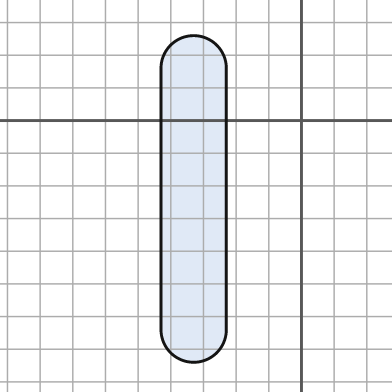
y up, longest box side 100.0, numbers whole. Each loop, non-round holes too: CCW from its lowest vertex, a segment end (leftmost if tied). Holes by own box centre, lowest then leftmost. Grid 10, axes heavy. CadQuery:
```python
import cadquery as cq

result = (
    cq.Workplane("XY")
    .moveTo(-43.0, -64.0)
    .threePointArc((-33.0, -74.0), (-23.0, -64.0))
    .lineTo(-23.0, 16.0)
    .threePointArc((-33.0, 26.0), (-43.0, 16.0))
    .close()
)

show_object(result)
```